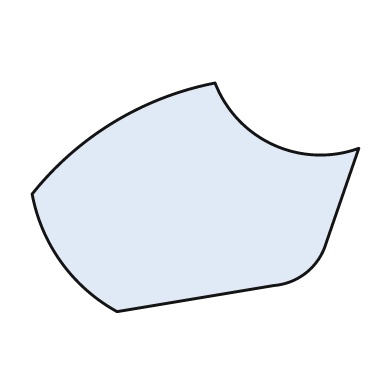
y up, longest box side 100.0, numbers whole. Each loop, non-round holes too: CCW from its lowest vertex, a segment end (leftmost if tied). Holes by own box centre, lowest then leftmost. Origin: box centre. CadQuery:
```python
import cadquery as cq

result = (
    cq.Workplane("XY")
    .moveTo(-24.0, -35.0)
    .lineTo(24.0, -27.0)
    .threePointArc((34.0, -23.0), (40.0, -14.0))
    .lineTo(50.0, 15.0)
    .threePointArc((24.0, 16.0), (6.0, 35.0))
    .threePointArc((-25.0, 23.0), (-50.0, 1.0))
    .threePointArc((-41.0, -20.0), (-24.0, -35.0))
    .close()
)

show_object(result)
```